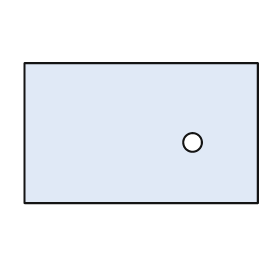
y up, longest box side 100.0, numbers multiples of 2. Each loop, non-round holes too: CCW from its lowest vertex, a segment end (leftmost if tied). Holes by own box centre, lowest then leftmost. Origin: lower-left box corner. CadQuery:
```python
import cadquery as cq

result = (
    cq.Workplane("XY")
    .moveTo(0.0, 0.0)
    .lineTo(100.0, 0.0)
    .lineTo(100.0, 60.0)
    .lineTo(0.0, 60.0)
    .close()
    .moveTo(72.0, 26.0)
    .circle(4.0)
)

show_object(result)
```